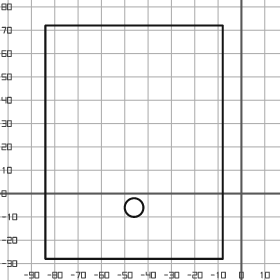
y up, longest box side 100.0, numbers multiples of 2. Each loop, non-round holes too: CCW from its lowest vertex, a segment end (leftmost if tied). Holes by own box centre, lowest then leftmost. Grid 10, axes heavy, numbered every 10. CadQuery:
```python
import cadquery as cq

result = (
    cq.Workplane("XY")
    .moveTo(-84.0, -28.0)
    .lineTo(-8.0, -28.0)
    .lineTo(-8.0, 72.0)
    .lineTo(-84.0, 72.0)
    .close()
    .moveTo(-46.0, -6.0)
    .circle(4.0)
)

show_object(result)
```